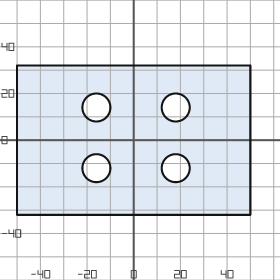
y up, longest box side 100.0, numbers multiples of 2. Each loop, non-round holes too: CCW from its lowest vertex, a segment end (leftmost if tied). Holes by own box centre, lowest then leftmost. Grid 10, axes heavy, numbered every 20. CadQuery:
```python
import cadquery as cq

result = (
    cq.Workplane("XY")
    .moveTo(-50.0, -32.0)
    .lineTo(50.0, -32.0)
    .lineTo(50.0, 32.0)
    .lineTo(-50.0, 32.0)
    .close()
    .moveTo(-16.0, -12.0)
    .circle(6.0)
    .moveTo(18.0, -12.0)
    .circle(6.0)
    .moveTo(-16.0, 14.0)
    .circle(6.0)
    .moveTo(18.0, 14.0)
    .circle(6.0)
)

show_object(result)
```